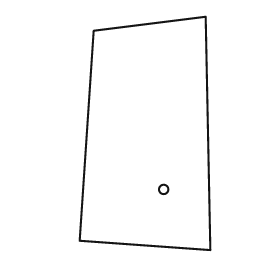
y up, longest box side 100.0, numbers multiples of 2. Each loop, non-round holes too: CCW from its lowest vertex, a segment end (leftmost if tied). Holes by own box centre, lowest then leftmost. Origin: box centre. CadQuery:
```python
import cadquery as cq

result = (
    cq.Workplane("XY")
    .moveTo(28.0, -50.0)
    .lineTo(26.0, 50.0)
    .lineTo(-22.0, 44.0)
    .lineTo(-28.0, -46.0)
    .close()
    .moveTo(8.0, -24.0)
    .circle(2.0)
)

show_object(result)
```